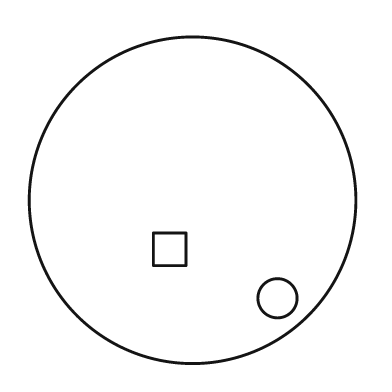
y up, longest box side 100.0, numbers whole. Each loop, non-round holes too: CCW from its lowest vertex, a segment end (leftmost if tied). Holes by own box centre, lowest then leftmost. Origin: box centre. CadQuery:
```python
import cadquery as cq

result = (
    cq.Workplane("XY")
    .moveTo(0.0, 0.0)
    .circle(50.0)
    .moveTo(26.0, -30.0)
    .circle(6.0)
    .moveTo(-12.0, -20.0)
    .lineTo(-2.0, -20.0)
    .lineTo(-2.0, -10.0)
    .lineTo(-12.0, -10.0)
    .close()
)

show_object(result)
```